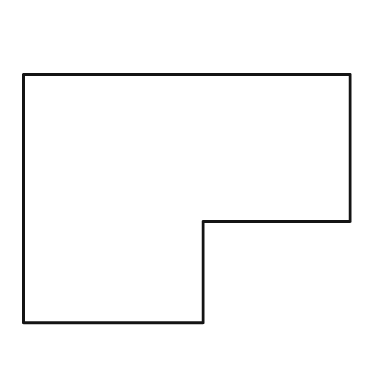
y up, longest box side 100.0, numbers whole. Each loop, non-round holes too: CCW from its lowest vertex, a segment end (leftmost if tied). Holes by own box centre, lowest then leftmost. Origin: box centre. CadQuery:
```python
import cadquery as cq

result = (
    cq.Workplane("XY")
    .moveTo(-50.0, -38.0)
    .lineTo(5.0, -38.0)
    .lineTo(5.0, -7.0)
    .lineTo(50.0, -7.0)
    .lineTo(50.0, 38.0)
    .lineTo(-50.0, 38.0)
    .close()
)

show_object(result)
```